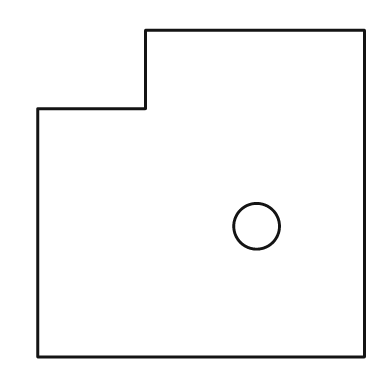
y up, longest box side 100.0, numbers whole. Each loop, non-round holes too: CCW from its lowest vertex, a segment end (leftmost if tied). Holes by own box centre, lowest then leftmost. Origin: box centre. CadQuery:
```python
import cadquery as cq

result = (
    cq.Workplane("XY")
    .moveTo(-50.0, -50.0)
    .lineTo(50.0, -50.0)
    .lineTo(50.0, 50.0)
    .lineTo(-17.0, 50.0)
    .lineTo(-17.0, 26.0)
    .lineTo(-50.0, 26.0)
    .close()
    .moveTo(17.0, -10.0)
    .circle(7.0)
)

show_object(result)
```